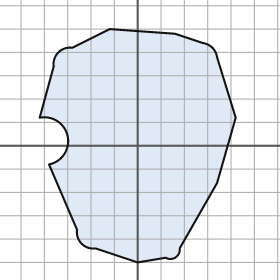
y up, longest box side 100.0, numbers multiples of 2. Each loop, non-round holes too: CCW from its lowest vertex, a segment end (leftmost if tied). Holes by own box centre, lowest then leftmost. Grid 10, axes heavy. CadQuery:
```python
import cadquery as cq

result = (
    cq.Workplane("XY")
    .moveTo(0.0, -50.0)
    .lineTo(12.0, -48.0)
    .threePointArc((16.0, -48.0), (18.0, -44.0))
    .lineTo(34.0, -16.0)
    .lineTo(42.0, 12.0)
    .lineTo(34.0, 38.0)
    .threePointArc((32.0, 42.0), (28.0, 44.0))
    .lineTo(16.0, 48.0)
    .lineTo(-12.0, 50.0)
    .lineTo(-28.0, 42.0)
    .threePointArc((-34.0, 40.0), (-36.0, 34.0))
    .lineTo(-42.0, 12.0)
    .threePointArc((-30.0, 4.0), (-38.0, -8.0))
    .lineTo(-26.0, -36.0)
    .threePointArc((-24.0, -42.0), (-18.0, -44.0))
    .close()
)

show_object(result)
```